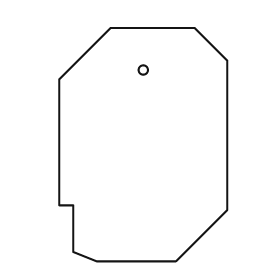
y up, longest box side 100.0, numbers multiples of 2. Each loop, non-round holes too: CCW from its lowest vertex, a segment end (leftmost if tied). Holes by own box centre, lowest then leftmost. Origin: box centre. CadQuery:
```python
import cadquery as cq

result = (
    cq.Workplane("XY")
    .moveTo(-20.0, -50.0)
    .lineTo(14.0, -50.0)
    .lineTo(36.0, -28.0)
    .lineTo(36.0, 36.0)
    .lineTo(22.0, 50.0)
    .lineTo(-14.0, 50.0)
    .lineTo(-36.0, 28.0)
    .lineTo(-36.0, -26.0)
    .lineTo(-30.0, -26.0)
    .lineTo(-30.0, -46.0)
    .close()
    .moveTo(0.0, 32.0)
    .circle(2.0)
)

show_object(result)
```